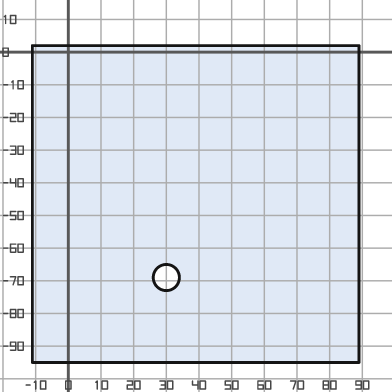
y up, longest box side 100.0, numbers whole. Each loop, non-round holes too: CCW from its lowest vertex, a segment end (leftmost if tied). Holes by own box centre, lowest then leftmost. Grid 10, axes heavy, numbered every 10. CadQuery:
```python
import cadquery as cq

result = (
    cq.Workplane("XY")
    .moveTo(-11.0, -95.0)
    .lineTo(89.0, -95.0)
    .lineTo(89.0, 2.0)
    .lineTo(-11.0, 2.0)
    .close()
    .moveTo(30.0, -69.0)
    .circle(4.0)
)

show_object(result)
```